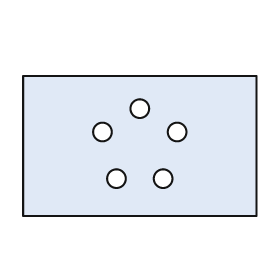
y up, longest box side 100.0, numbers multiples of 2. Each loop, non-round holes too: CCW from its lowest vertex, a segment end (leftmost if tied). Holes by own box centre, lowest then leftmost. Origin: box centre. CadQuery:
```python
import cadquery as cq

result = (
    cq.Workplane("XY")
    .moveTo(-50.0, -30.0)
    .lineTo(50.0, -30.0)
    .lineTo(50.0, 30.0)
    .lineTo(-50.0, 30.0)
    .close()
    .moveTo(-10.0, -14.0)
    .circle(4.0)
    .moveTo(10.0, -14.0)
    .circle(4.0)
    .moveTo(-16.0, 6.0)
    .circle(4.0)
    .moveTo(16.0, 6.0)
    .circle(4.0)
    .moveTo(0.0, 16.0)
    .circle(4.0)
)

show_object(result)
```